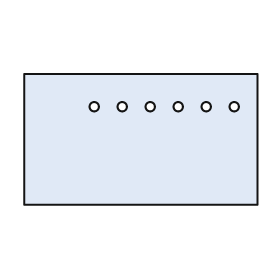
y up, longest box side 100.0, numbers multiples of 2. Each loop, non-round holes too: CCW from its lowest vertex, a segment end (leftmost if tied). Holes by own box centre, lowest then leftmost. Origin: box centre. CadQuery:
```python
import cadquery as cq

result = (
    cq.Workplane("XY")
    .moveTo(-50.0, -28.0)
    .lineTo(50.0, -28.0)
    .lineTo(50.0, 28.0)
    .lineTo(-50.0, 28.0)
    .close()
    .moveTo(-20.0, 14.0)
    .circle(2.0)
    .moveTo(-8.0, 14.0)
    .circle(2.0)
    .moveTo(4.0, 14.0)
    .circle(2.0)
    .moveTo(16.0, 14.0)
    .circle(2.0)
    .moveTo(28.0, 14.0)
    .circle(2.0)
    .moveTo(40.0, 14.0)
    .circle(2.0)
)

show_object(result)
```